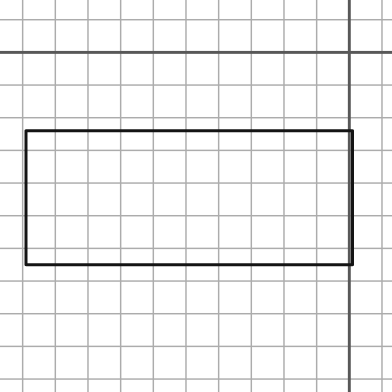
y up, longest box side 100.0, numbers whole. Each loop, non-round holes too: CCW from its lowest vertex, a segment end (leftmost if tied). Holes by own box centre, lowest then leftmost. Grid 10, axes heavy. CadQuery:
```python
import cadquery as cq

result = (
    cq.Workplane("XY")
    .moveTo(-99.0, -65.0)
    .lineTo(1.0, -65.0)
    .lineTo(1.0, -24.0)
    .lineTo(-99.0, -24.0)
    .close()
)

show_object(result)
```